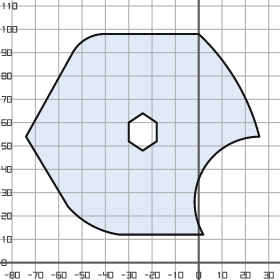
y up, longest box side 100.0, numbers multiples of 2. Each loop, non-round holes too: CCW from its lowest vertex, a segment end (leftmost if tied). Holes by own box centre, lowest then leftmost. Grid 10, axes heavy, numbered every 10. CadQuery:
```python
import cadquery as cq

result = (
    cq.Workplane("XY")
    .moveTo(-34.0, 12.0)
    .lineTo(2.0, 12.0)
    .threePointArc((2.0, 40.0), (26.0, 54.0))
    .threePointArc((16.0, 78.0), (0.0, 98.0))
    .lineTo(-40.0, 98.0)
    .threePointArc((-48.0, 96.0), (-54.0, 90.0))
    .lineTo(-74.0, 54.0)
    .lineTo(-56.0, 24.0)
    .threePointArc((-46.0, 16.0), (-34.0, 12.0))
    .close()
    .moveTo(-24.0, 48.0)
    .lineTo(-18.0, 52.0)
    .lineTo(-18.0, 60.0)
    .lineTo(-24.0, 64.0)
    .lineTo(-30.0, 60.0)
    .lineTo(-30.0, 52.0)
    .close()
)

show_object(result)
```